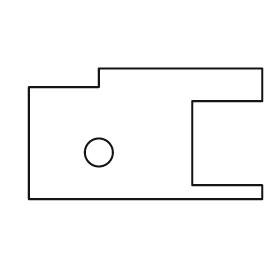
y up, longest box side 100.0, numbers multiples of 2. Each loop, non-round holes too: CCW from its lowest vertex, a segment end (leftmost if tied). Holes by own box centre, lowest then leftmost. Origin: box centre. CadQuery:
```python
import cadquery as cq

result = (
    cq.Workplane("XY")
    .moveTo(-50.0, -28.0)
    .lineTo(50.0, -28.0)
    .lineTo(50.0, -22.0)
    .lineTo(20.0, -22.0)
    .lineTo(20.0, 14.0)
    .lineTo(50.0, 14.0)
    .lineTo(50.0, 28.0)
    .lineTo(-20.0, 28.0)
    .lineTo(-20.0, 20.0)
    .lineTo(-50.0, 20.0)
    .close()
    .moveTo(-20.0, -8.0)
    .circle(6.0)
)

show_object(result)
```